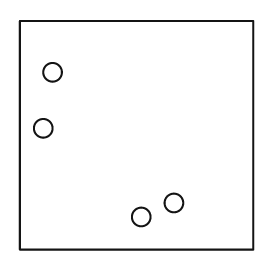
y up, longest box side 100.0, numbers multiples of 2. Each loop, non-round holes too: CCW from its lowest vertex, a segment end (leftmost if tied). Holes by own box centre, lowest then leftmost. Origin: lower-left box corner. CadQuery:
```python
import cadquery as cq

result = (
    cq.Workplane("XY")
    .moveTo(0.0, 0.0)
    .lineTo(100.0, 0.0)
    .lineTo(100.0, 98.0)
    .lineTo(0.0, 98.0)
    .close()
    .moveTo(52.0, 14.0)
    .circle(4.0)
    .moveTo(66.0, 20.0)
    .circle(4.0)
    .moveTo(10.0, 52.0)
    .circle(4.0)
    .moveTo(14.0, 76.0)
    .circle(4.0)
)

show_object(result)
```